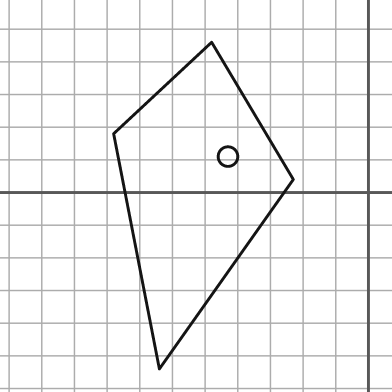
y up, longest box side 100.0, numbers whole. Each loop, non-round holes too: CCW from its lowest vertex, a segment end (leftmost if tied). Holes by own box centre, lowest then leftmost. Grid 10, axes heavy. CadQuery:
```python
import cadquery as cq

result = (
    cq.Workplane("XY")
    .moveTo(-64.0, -54.0)
    .lineTo(-23.0, 4.0)
    .lineTo(-48.0, 46.0)
    .lineTo(-78.0, 18.0)
    .close()
    .moveTo(-43.0, 11.0)
    .circle(3.0)
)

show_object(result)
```